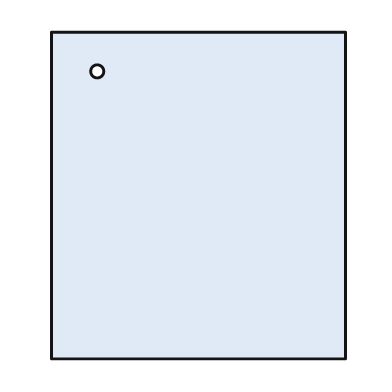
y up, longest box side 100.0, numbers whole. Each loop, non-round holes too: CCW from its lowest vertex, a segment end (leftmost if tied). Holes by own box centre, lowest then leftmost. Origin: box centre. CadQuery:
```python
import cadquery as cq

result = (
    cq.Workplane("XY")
    .moveTo(-45.0, -50.0)
    .lineTo(45.0, -50.0)
    .lineTo(45.0, 50.0)
    .lineTo(-45.0, 50.0)
    .close()
    .moveTo(-31.0, 38.0)
    .circle(2.0)
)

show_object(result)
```